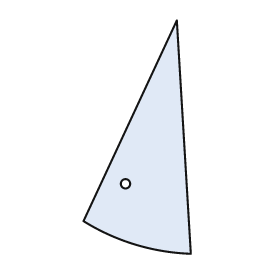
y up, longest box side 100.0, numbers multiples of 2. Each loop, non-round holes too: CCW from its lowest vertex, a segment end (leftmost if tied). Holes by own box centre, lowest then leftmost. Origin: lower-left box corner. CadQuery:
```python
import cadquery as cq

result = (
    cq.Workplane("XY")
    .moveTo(46.0, 0.0)
    .lineTo(40.0, 100.0)
    .lineTo(0.0, 14.0)
    .threePointArc((22.0, 4.0), (46.0, 0.0))
    .close()
    .moveTo(18.0, 30.0)
    .circle(2.0)
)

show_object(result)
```